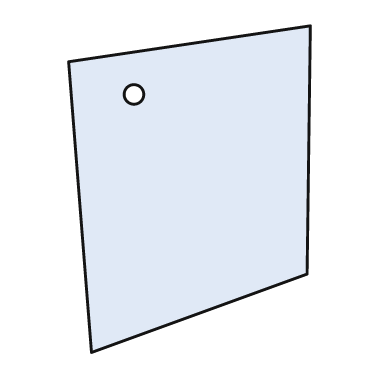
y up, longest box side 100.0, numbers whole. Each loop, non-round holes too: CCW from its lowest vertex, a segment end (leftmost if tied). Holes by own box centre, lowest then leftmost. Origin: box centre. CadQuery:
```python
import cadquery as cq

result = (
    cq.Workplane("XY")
    .moveTo(-30.0, -50.0)
    .lineTo(36.0, -26.0)
    .lineTo(37.0, 50.0)
    .lineTo(-37.0, 39.0)
    .close()
    .moveTo(-17.0, 29.0)
    .circle(3.0)
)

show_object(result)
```